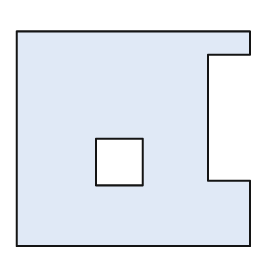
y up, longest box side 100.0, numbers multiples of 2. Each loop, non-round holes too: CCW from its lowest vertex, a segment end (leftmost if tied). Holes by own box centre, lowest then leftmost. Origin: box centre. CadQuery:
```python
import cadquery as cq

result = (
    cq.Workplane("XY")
    .moveTo(-50.0, -46.0)
    .lineTo(50.0, -46.0)
    .lineTo(50.0, -18.0)
    .lineTo(32.0, -18.0)
    .lineTo(32.0, 36.0)
    .lineTo(50.0, 36.0)
    .lineTo(50.0, 46.0)
    .lineTo(-50.0, 46.0)
    .close()
    .moveTo(-16.0, -20.0)
    .lineTo(4.0, -20.0)
    .lineTo(4.0, 0.0)
    .lineTo(-16.0, 0.0)
    .close()
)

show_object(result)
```